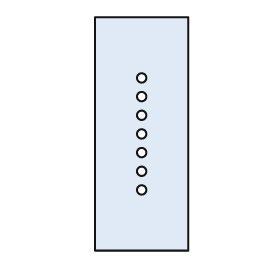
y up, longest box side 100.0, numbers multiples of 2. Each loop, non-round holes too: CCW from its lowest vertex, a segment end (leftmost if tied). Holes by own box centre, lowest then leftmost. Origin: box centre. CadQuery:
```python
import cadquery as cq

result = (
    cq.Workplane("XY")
    .moveTo(-20.0, -50.0)
    .lineTo(20.0, -50.0)
    .lineTo(20.0, 50.0)
    .lineTo(-20.0, 50.0)
    .close()
    .moveTo(0.0, -24.0)
    .circle(2.0)
    .moveTo(0.0, -16.0)
    .circle(2.0)
    .moveTo(0.0, -8.0)
    .circle(2.0)
    .moveTo(0.0, 0.0)
    .circle(2.0)
    .moveTo(0.0, 8.0)
    .circle(2.0)
    .moveTo(0.0, 16.0)
    .circle(2.0)
    .moveTo(0.0, 24.0)
    .circle(2.0)
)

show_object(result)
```